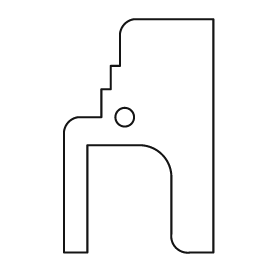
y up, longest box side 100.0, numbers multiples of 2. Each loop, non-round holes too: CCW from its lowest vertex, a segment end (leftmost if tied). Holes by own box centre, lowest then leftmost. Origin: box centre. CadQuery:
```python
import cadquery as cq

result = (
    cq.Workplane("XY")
    .moveTo(-32.0, -50.0)
    .lineTo(-22.0, -50.0)
    .lineTo(-22.0, -4.0)
    .lineTo(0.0, -4.0)
    .threePointArc((10.0, -8.0), (14.0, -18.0))
    .lineTo(14.0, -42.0)
    .threePointArc((16.0, -48.0), (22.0, -50.0))
    .lineTo(32.0, -50.0)
    .lineTo(32.0, 50.0)
    .lineTo(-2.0, 50.0)
    .threePointArc((-6.0, 48.0), (-8.0, 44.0))
    .lineTo(-8.0, 30.0)
    .lineTo(-12.0, 30.0)
    .lineTo(-12.0, 20.0)
    .lineTo(-16.0, 20.0)
    .lineTo(-16.0, 8.0)
    .lineTo(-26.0, 8.0)
    .threePointArc((-30.0, 6.0), (-32.0, 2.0))
    .close()
    .moveTo(-6.0, 8.0)
    .circle(4.0)
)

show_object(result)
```